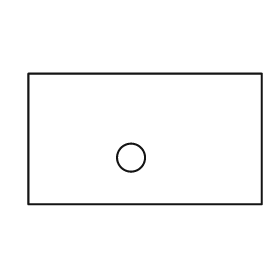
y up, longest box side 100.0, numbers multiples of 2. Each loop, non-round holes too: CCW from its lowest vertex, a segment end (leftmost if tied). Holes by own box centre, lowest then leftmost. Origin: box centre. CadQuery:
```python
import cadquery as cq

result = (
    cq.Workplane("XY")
    .moveTo(-50.0, -28.0)
    .lineTo(50.0, -28.0)
    .lineTo(50.0, 28.0)
    .lineTo(-50.0, 28.0)
    .close()
    .moveTo(-6.0, -8.0)
    .circle(6.0)
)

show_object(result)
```